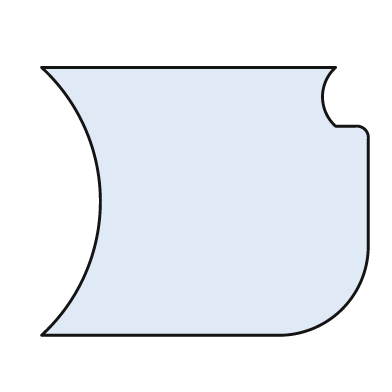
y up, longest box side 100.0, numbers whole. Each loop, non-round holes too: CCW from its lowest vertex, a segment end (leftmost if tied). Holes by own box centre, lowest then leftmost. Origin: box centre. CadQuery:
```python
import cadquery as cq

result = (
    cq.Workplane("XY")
    .moveTo(-50.0, -41.0)
    .lineTo(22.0, -41.0)
    .threePointArc((42.0, -33.0), (50.0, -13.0))
    .lineTo(50.0, 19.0)
    .threePointArc((49.0, 22.0), (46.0, 23.0))
    .lineTo(40.0, 23.0)
    .threePointArc((36.0, 32.0), (40.0, 41.0))
    .lineTo(-50.0, 41.0)
    .threePointArc((-32.0, 0.0), (-50.0, -41.0))
    .close()
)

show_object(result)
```